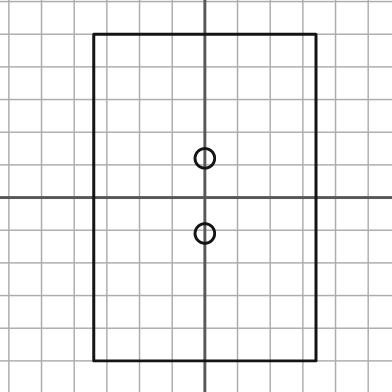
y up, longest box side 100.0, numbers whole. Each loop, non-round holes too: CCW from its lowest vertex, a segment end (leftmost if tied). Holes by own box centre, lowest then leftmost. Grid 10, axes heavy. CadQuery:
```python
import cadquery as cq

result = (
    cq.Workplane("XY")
    .moveTo(-34.0, -50.0)
    .lineTo(34.0, -50.0)
    .lineTo(34.0, 50.0)
    .lineTo(-34.0, 50.0)
    .close()
    .moveTo(0.0, -11.0)
    .circle(3.0)
    .moveTo(0.0, 12.0)
    .circle(3.0)
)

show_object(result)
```